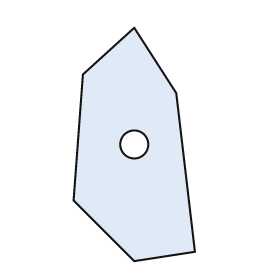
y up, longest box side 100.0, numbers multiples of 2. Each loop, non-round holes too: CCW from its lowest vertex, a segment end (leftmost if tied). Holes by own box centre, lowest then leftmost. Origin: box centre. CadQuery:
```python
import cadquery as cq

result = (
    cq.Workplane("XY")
    .moveTo(0.0, -50.0)
    .lineTo(26.0, -46.0)
    .lineTo(18.0, 22.0)
    .lineTo(0.0, 50.0)
    .lineTo(-22.0, 30.0)
    .lineTo(-26.0, -24.0)
    .close()
    .moveTo(0.0, 0.0)
    .circle(6.0)
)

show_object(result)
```